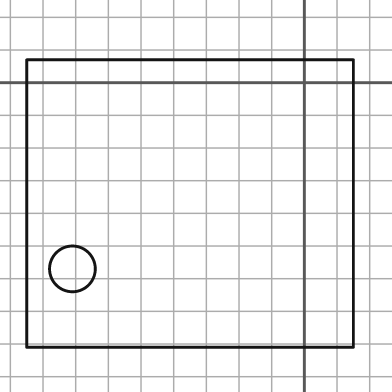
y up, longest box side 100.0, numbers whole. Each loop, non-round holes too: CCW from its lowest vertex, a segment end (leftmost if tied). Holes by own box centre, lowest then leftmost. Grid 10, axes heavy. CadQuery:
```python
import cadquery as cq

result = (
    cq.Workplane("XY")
    .moveTo(-85.0, -81.0)
    .lineTo(15.0, -81.0)
    .lineTo(15.0, 7.0)
    .lineTo(-85.0, 7.0)
    .close()
    .moveTo(-71.0, -57.0)
    .circle(7.0)
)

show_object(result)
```